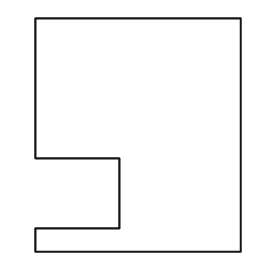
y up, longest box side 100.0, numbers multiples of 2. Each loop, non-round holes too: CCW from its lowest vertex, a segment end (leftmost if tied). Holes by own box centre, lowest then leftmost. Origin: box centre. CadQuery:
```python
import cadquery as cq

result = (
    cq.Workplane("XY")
    .moveTo(-44.0, -50.0)
    .lineTo(44.0, -50.0)
    .lineTo(44.0, 50.0)
    .lineTo(-44.0, 50.0)
    .lineTo(-44.0, -10.0)
    .lineTo(-8.0, -10.0)
    .lineTo(-8.0, -40.0)
    .lineTo(-44.0, -40.0)
    .close()
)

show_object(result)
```